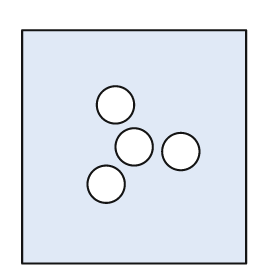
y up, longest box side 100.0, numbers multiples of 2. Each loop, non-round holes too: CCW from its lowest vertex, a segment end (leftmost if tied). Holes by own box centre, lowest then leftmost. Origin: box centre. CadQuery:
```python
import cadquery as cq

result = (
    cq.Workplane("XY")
    .moveTo(-48.0, -50.0)
    .lineTo(48.0, -50.0)
    .lineTo(48.0, 50.0)
    .lineTo(-48.0, 50.0)
    .close()
    .moveTo(-12.0, -16.0)
    .circle(8.0)
    .moveTo(20.0, -2.0)
    .circle(8.0)
    .moveTo(0.0, 0.0)
    .circle(8.0)
    .moveTo(-8.0, 18.0)
    .circle(8.0)
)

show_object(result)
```